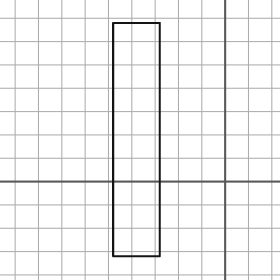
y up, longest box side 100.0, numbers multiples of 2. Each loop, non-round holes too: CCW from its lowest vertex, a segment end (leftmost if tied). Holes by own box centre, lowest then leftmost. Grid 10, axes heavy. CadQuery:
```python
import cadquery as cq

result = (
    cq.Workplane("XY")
    .moveTo(-48.0, -32.0)
    .lineTo(-28.0, -32.0)
    .lineTo(-28.0, 68.0)
    .lineTo(-48.0, 68.0)
    .close()
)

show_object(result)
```